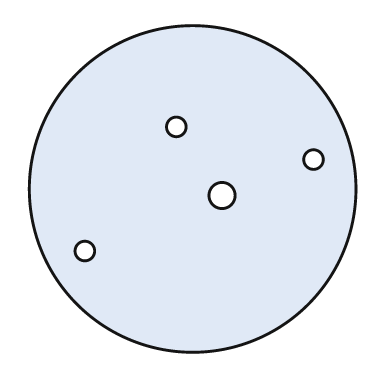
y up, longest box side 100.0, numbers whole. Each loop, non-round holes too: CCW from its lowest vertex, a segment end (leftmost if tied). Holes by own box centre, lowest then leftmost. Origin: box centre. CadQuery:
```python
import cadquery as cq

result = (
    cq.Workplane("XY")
    .moveTo(0.0, 0.0)
    .circle(50.0)
    .moveTo(-33.0, -19.0)
    .circle(3.0)
    .moveTo(9.0, -2.0)
    .circle(4.0)
    .moveTo(37.0, 9.0)
    .circle(3.0)
    .moveTo(-5.0, 19.0)
    .circle(3.0)
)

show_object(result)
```